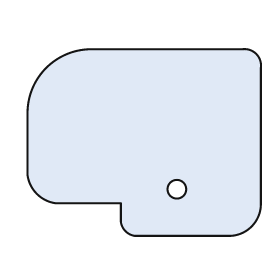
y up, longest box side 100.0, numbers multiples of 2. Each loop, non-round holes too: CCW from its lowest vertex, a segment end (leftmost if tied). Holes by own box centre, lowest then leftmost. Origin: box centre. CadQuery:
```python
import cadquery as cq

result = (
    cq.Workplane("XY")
    .moveTo(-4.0, -40.0)
    .lineTo(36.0, -40.0)
    .threePointArc((46.0, -36.0), (50.0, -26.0))
    .lineTo(50.0, 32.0)
    .threePointArc((48.0, 38.0), (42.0, 40.0))
    .lineTo(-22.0, 40.0)
    .threePointArc((-42.0, 32.0), (-50.0, 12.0))
    .lineTo(-50.0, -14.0)
    .threePointArc((-46.0, -22.0), (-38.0, -26.0))
    .lineTo(-10.0, -26.0)
    .lineTo(-10.0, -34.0)
    .threePointArc((-8.0, -38.0), (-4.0, -40.0))
    .close()
    .moveTo(14.0, -20.0)
    .circle(4.0)
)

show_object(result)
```